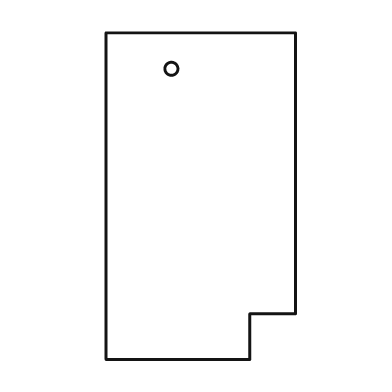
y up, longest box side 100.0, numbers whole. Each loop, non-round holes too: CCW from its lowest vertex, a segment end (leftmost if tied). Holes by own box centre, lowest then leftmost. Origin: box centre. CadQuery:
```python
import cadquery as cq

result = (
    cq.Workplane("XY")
    .moveTo(-29.0, -50.0)
    .lineTo(15.0, -50.0)
    .lineTo(15.0, -36.0)
    .lineTo(29.0, -36.0)
    .lineTo(29.0, 50.0)
    .lineTo(-29.0, 50.0)
    .close()
    .moveTo(-9.0, 39.0)
    .circle(2.0)
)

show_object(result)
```